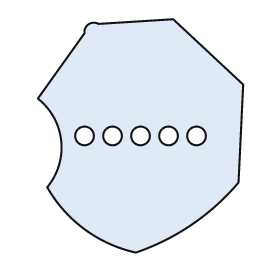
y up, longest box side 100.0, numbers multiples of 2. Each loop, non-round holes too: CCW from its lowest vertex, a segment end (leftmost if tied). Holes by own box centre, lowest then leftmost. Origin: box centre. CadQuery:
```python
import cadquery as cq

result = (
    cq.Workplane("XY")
    .moveTo(-2.0, -50.0)
    .threePointArc((22.0, -38.0), (42.0, -20.0))
    .lineTo(44.0, 22.0)
    .lineTo(14.0, 50.0)
    .lineTo(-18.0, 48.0)
    .threePointArc((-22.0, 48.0), (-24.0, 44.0))
    .lineTo(-44.0, 16.0)
    .threePointArc((-34.0, -2.0), (-40.0, -22.0))
    .threePointArc((-24.0, -40.0), (-2.0, -50.0))
    .close()
    .moveTo(-24.0, 0.0)
    .circle(4.0)
    .moveTo(-12.0, 0.0)
    .circle(4.0)
    .moveTo(0.0, 0.0)
    .circle(4.0)
    .moveTo(12.0, 0.0)
    .circle(4.0)
    .moveTo(24.0, 0.0)
    .circle(4.0)
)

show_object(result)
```